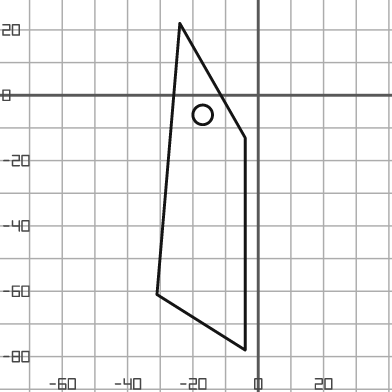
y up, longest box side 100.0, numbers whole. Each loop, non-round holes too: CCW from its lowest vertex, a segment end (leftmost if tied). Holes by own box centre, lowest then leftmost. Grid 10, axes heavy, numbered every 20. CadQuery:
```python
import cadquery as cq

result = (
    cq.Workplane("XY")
    .moveTo(-4.0, -78.0)
    .lineTo(-4.0, -13.0)
    .lineTo(-24.0, 22.0)
    .lineTo(-31.0, -61.0)
    .close()
    .moveTo(-17.0, -6.0)
    .circle(3.0)
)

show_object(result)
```